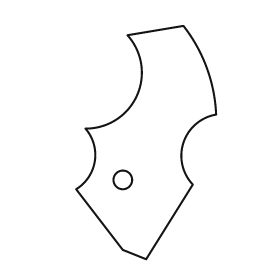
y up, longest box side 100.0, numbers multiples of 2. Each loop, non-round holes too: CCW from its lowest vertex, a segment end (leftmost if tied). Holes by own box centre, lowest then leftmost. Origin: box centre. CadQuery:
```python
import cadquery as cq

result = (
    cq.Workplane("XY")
    .moveTo(0.0, -50.0)
    .lineTo(20.0, -18.0)
    .threePointArc((16.0, 0.0), (30.0, 12.0))
    .threePointArc((26.0, 32.0), (16.0, 50.0))
    .lineTo(-8.0, 46.0)
    .threePointArc((-4.0, 20.0), (-26.0, 6.0))
    .threePointArc((-22.0, -8.0), (-30.0, -20.0))
    .lineTo(-10.0, -46.0)
    .close()
    .moveTo(-10.0, -16.0)
    .circle(4.0)
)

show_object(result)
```